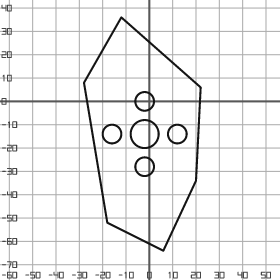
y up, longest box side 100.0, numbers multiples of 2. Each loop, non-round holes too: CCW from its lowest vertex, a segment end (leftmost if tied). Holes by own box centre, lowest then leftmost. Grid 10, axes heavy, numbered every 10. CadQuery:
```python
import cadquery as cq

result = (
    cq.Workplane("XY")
    .moveTo(6.0, -64.0)
    .lineTo(20.0, -34.0)
    .lineTo(22.0, 6.0)
    .lineTo(-12.0, 36.0)
    .lineTo(-28.0, 8.0)
    .lineTo(-18.0, -52.0)
    .close()
    .moveTo(-2.0, -28.0)
    .circle(4.0)
    .moveTo(-16.0, -14.0)
    .circle(4.0)
    .moveTo(-2.0, -14.0)
    .circle(6.0)
    .moveTo(12.0, -14.0)
    .circle(4.0)
    .moveTo(-2.0, 0.0)
    .circle(4.0)
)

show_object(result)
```